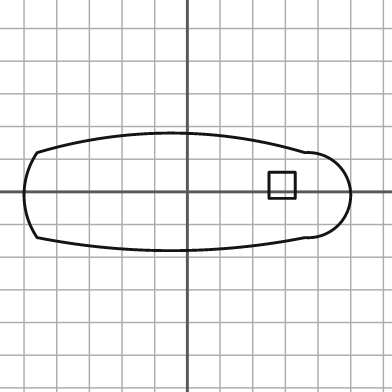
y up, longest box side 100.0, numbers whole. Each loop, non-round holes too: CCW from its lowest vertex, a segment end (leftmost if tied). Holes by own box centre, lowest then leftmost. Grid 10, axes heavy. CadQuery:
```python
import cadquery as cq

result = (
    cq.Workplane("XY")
    .moveTo(-46.0, -14.0)
    .threePointArc((-5.0, -18.0), (36.0, -14.0))
    .threePointArc((50.0, -1.0), (36.0, 12.0))
    .threePointArc((-5.0, 18.0), (-46.0, 12.0))
    .threePointArc((-50.0, -1.0), (-46.0, -14.0))
    .close()
    .moveTo(25.0, -2.0)
    .lineTo(33.0, -2.0)
    .lineTo(33.0, 6.0)
    .lineTo(25.0, 6.0)
    .close()
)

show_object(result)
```